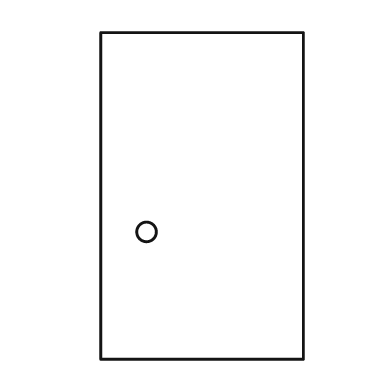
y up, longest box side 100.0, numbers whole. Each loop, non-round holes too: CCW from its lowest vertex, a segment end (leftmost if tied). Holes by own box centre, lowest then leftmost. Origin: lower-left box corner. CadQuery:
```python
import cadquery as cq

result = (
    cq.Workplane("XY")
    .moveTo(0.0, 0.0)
    .lineTo(62.0, 0.0)
    .lineTo(62.0, 100.0)
    .lineTo(0.0, 100.0)
    .close()
    .moveTo(14.0, 39.0)
    .circle(3.0)
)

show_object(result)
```